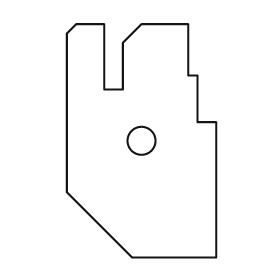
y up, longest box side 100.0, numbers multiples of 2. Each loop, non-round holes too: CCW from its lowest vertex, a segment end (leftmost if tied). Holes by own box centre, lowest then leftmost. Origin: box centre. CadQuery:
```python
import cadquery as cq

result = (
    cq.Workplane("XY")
    .moveTo(-4.0, -50.0)
    .lineTo(32.0, -50.0)
    .lineTo(32.0, 8.0)
    .lineTo(24.0, 8.0)
    .lineTo(24.0, 28.0)
    .lineTo(20.0, 28.0)
    .lineTo(20.0, 50.0)
    .lineTo(0.0, 50.0)
    .lineTo(-8.0, 42.0)
    .lineTo(-8.0, 22.0)
    .lineTo(-16.0, 22.0)
    .lineTo(-16.0, 50.0)
    .lineTo(-28.0, 50.0)
    .lineTo(-32.0, 46.0)
    .lineTo(-32.0, -22.0)
    .close()
    .moveTo(0.0, 0.0)
    .circle(6.0)
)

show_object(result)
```